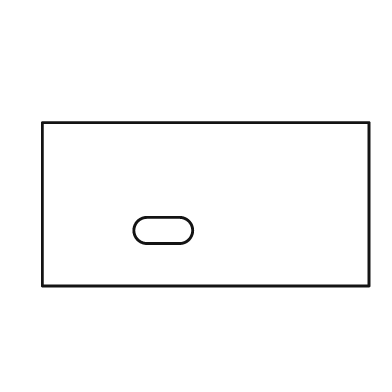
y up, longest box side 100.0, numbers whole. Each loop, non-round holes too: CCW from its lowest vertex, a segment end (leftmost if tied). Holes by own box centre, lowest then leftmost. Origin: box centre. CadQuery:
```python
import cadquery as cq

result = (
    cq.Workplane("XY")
    .moveTo(-50.0, -25.0)
    .lineTo(50.0, -25.0)
    .lineTo(50.0, 25.0)
    .lineTo(-50.0, 25.0)
    .close()
    .moveTo(-18.0, -12.0)
    .lineTo(-8.0, -12.0)
    .threePointArc((-4.0, -8.0), (-8.0, -4.0))
    .lineTo(-18.0, -4.0)
    .threePointArc((-22.0, -8.0), (-18.0, -12.0))
    .close()
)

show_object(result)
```